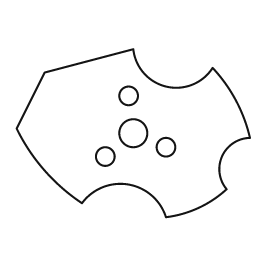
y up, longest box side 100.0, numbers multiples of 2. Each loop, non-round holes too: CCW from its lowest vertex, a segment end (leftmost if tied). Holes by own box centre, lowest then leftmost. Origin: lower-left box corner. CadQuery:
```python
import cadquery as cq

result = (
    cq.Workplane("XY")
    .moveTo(64.0, 0.0)
    .threePointArc((78.0, 4.0), (90.0, 12.0))
    .threePointArc((88.0, 26.0), (100.0, 34.0))
    .threePointArc((94.0, 50.0), (84.0, 64.0))
    .threePointArc((64.0, 56.0), (50.0, 72.0))
    .lineTo(12.0, 62.0)
    .lineTo(0.0, 38.0)
    .threePointArc((12.0, 20.0), (28.0, 6.0))
    .threePointArc((48.0, 14.0), (64.0, 0.0))
    .close()
    .moveTo(38.0, 26.0)
    .circle(4.0)
    .moveTo(64.0, 30.0)
    .circle(4.0)
    .moveTo(50.0, 36.0)
    .circle(6.0)
    .moveTo(48.0, 52.0)
    .circle(4.0)
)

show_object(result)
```